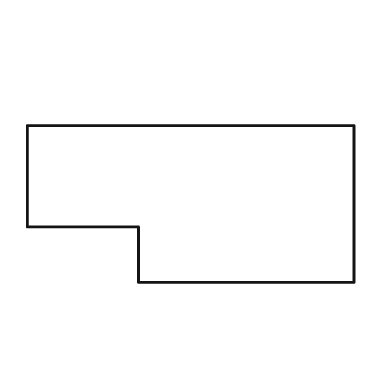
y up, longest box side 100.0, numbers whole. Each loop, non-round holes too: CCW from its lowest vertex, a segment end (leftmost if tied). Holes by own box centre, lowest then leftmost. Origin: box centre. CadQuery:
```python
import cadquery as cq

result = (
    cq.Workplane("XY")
    .moveTo(-16.0, -24.0)
    .lineTo(50.0, -24.0)
    .lineTo(50.0, 24.0)
    .lineTo(-50.0, 24.0)
    .lineTo(-50.0, -7.0)
    .lineTo(-16.0, -7.0)
    .close()
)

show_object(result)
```